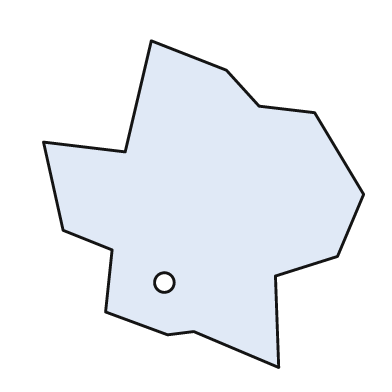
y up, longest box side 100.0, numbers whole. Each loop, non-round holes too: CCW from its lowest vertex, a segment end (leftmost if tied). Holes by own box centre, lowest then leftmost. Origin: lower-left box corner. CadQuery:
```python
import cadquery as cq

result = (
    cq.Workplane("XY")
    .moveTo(72.0, 0.0)
    .lineTo(71.0, 28.0)
    .lineTo(90.0, 34.0)
    .lineTo(98.0, 53.0)
    .lineTo(83.0, 78.0)
    .lineTo(66.0, 80.0)
    .lineTo(56.0, 91.0)
    .lineTo(33.0, 100.0)
    .lineTo(25.0, 66.0)
    .lineTo(0.0, 69.0)
    .lineTo(6.0, 42.0)
    .lineTo(21.0, 36.0)
    .lineTo(19.0, 17.0)
    .lineTo(38.0, 10.0)
    .lineTo(46.0, 11.0)
    .close()
    .moveTo(37.0, 26.0)
    .circle(3.0)
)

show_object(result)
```